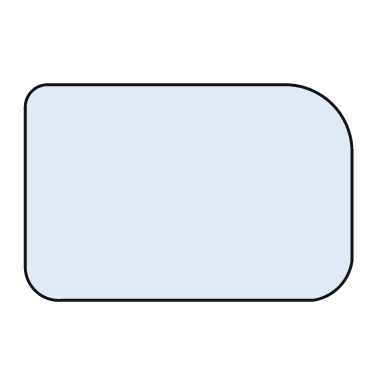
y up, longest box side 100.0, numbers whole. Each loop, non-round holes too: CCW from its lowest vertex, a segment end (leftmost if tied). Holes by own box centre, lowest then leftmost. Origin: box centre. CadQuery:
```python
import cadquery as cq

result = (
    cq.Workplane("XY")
    .moveTo(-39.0, -33.0)
    .lineTo(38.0, -33.0)
    .threePointArc((46.0, -29.0), (50.0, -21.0))
    .lineTo(50.0, 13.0)
    .threePointArc((44.0, 27.0), (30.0, 33.0))
    .lineTo(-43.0, 33.0)
    .threePointArc((-48.0, 31.0), (-50.0, 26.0))
    .lineTo(-50.0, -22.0)
    .threePointArc((-47.0, -30.0), (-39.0, -33.0))
    .close()
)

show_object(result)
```